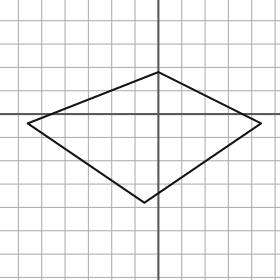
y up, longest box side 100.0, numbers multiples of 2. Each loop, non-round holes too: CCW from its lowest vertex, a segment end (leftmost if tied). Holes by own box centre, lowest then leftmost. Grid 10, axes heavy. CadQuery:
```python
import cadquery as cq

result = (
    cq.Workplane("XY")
    .moveTo(-6.0, -38.0)
    .lineTo(44.0, -4.0)
    .lineTo(0.0, 18.0)
    .lineTo(-56.0, -4.0)
    .close()
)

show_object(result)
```